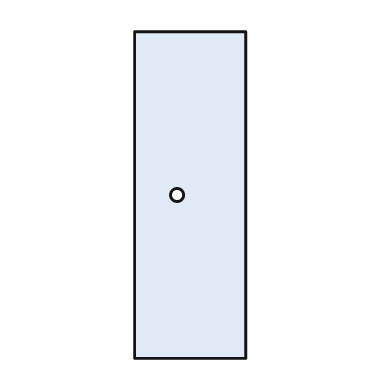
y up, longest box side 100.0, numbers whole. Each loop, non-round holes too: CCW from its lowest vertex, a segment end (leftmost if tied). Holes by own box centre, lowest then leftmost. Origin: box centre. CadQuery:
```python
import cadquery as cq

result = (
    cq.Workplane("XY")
    .moveTo(-17.0, -50.0)
    .lineTo(17.0, -50.0)
    .lineTo(17.0, 50.0)
    .lineTo(-17.0, 50.0)
    .close()
    .moveTo(-4.0, 0.0)
    .circle(2.0)
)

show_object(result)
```